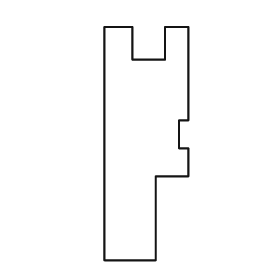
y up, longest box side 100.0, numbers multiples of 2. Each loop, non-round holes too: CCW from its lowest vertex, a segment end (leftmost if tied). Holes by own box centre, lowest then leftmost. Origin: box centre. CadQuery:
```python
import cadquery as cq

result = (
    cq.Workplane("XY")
    .moveTo(-18.0, -50.0)
    .lineTo(4.0, -50.0)
    .lineTo(4.0, -14.0)
    .lineTo(18.0, -14.0)
    .lineTo(18.0, -2.0)
    .lineTo(14.0, -2.0)
    .lineTo(14.0, 10.0)
    .lineTo(18.0, 10.0)
    .lineTo(18.0, 50.0)
    .lineTo(8.0, 50.0)
    .lineTo(8.0, 36.0)
    .lineTo(-6.0, 36.0)
    .lineTo(-6.0, 50.0)
    .lineTo(-18.0, 50.0)
    .close()
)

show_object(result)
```